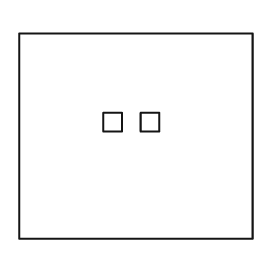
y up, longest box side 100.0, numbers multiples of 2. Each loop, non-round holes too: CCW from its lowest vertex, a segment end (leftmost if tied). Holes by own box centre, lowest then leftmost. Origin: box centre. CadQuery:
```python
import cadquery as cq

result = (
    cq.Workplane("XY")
    .moveTo(-50.0, -44.0)
    .lineTo(50.0, -44.0)
    .lineTo(50.0, 44.0)
    .lineTo(-50.0, 44.0)
    .close()
    .moveTo(-14.0, 2.0)
    .lineTo(-6.0, 2.0)
    .lineTo(-6.0, 10.0)
    .lineTo(-14.0, 10.0)
    .close()
    .moveTo(2.0, 2.0)
    .lineTo(10.0, 2.0)
    .lineTo(10.0, 10.0)
    .lineTo(2.0, 10.0)
    .close()
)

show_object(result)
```